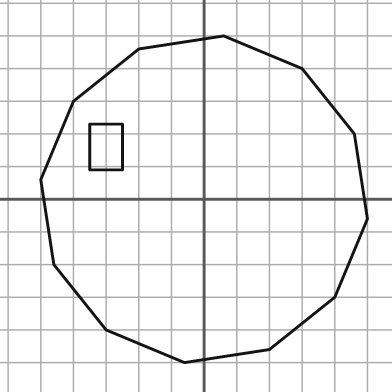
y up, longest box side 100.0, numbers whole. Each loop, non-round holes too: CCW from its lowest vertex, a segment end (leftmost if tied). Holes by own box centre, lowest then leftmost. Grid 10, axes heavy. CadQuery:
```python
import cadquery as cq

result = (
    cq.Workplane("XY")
    .moveTo(-6.0, -50.0)
    .lineTo(20.0, -46.0)
    .lineTo(40.0, -30.0)
    .lineTo(50.0, -6.0)
    .lineTo(46.0, 20.0)
    .lineTo(30.0, 40.0)
    .lineTo(6.0, 50.0)
    .lineTo(-20.0, 46.0)
    .lineTo(-40.0, 30.0)
    .lineTo(-50.0, 6.0)
    .lineTo(-46.0, -20.0)
    .lineTo(-30.0, -40.0)
    .close()
    .moveTo(-35.0, 9.0)
    .lineTo(-25.0, 9.0)
    .lineTo(-25.0, 23.0)
    .lineTo(-35.0, 23.0)
    .close()
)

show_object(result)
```